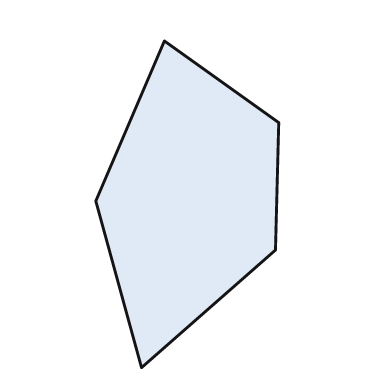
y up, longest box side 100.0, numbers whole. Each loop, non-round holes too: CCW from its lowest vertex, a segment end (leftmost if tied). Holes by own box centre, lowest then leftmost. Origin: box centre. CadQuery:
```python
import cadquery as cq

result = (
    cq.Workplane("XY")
    .moveTo(-14.0, -50.0)
    .lineTo(27.0, -14.0)
    .lineTo(28.0, 25.0)
    .lineTo(-7.0, 50.0)
    .lineTo(-28.0, 1.0)
    .close()
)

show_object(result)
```